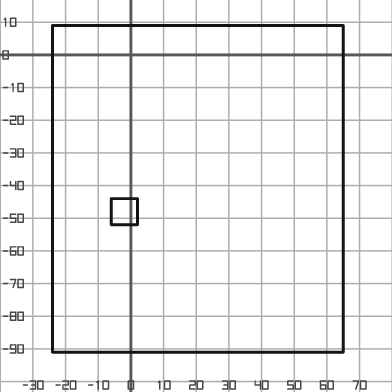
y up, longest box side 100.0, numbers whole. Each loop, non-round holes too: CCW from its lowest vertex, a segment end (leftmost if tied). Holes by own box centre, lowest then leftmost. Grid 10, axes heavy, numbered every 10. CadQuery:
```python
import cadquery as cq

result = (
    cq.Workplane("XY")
    .moveTo(-24.0, -91.0)
    .lineTo(65.0, -91.0)
    .lineTo(65.0, 9.0)
    .lineTo(-24.0, 9.0)
    .close()
    .moveTo(-6.0, -52.0)
    .lineTo(2.0, -52.0)
    .lineTo(2.0, -44.0)
    .lineTo(-6.0, -44.0)
    .close()
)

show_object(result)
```